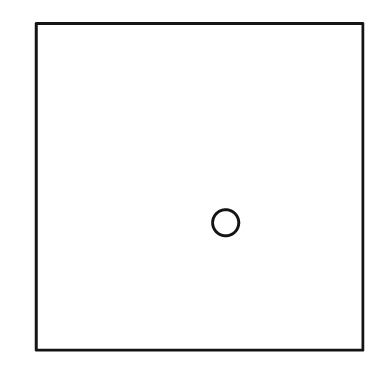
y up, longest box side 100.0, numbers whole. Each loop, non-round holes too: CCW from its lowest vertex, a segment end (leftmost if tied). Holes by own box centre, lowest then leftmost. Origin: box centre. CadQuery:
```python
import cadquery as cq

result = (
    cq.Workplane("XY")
    .moveTo(-50.0, -50.0)
    .lineTo(50.0, -50.0)
    .lineTo(50.0, 50.0)
    .lineTo(-50.0, 50.0)
    .close()
    .moveTo(8.0, -11.0)
    .circle(4.0)
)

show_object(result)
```